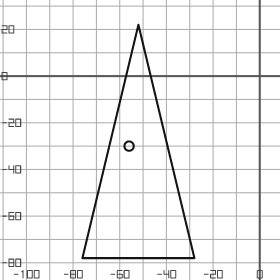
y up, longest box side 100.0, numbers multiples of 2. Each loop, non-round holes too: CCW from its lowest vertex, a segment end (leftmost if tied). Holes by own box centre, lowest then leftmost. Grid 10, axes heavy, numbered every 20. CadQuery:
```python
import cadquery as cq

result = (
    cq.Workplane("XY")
    .moveTo(-76.0, -78.0)
    .lineTo(-28.0, -78.0)
    .lineTo(-52.0, 22.0)
    .close()
    .moveTo(-56.0, -30.0)
    .circle(2.0)
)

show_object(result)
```